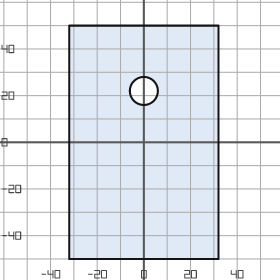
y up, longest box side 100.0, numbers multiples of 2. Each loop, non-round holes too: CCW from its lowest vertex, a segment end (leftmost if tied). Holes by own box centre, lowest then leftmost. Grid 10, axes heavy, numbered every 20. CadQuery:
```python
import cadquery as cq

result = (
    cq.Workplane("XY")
    .moveTo(-32.0, -50.0)
    .lineTo(32.0, -50.0)
    .lineTo(32.0, 50.0)
    .lineTo(-32.0, 50.0)
    .close()
    .moveTo(0.0, 22.0)
    .circle(6.0)
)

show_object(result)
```